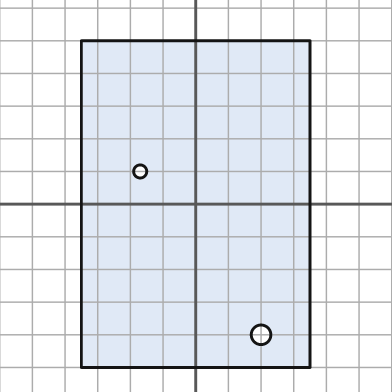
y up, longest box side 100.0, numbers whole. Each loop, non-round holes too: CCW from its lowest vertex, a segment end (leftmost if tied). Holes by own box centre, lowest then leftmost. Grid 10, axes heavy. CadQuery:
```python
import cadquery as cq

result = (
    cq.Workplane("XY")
    .moveTo(-35.0, -50.0)
    .lineTo(35.0, -50.0)
    .lineTo(35.0, 50.0)
    .lineTo(-35.0, 50.0)
    .close()
    .moveTo(20.0, -40.0)
    .circle(3.0)
    .moveTo(-17.0, 10.0)
    .circle(2.0)
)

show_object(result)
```